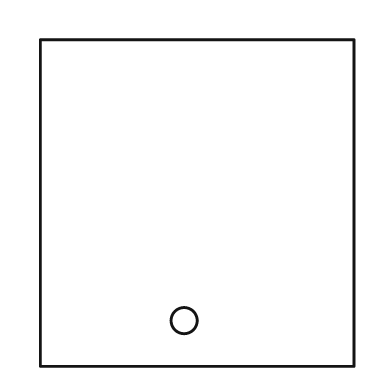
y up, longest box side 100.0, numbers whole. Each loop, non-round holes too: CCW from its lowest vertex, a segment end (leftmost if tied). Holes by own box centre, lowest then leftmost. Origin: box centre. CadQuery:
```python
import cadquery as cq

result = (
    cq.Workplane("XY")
    .moveTo(-48.0, -50.0)
    .lineTo(48.0, -50.0)
    .lineTo(48.0, 50.0)
    .lineTo(-48.0, 50.0)
    .close()
    .moveTo(-4.0, -36.0)
    .circle(4.0)
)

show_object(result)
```